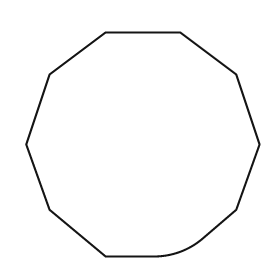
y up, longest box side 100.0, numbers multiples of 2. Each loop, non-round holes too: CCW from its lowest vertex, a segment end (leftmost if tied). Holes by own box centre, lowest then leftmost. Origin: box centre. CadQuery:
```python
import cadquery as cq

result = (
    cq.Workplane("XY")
    .moveTo(-16.0, -48.0)
    .lineTo(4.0, -48.0)
    .threePointArc((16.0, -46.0), (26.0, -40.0))
    .lineTo(40.0, -28.0)
    .lineTo(50.0, 0.0)
    .lineTo(40.0, 30.0)
    .lineTo(16.0, 48.0)
    .lineTo(-16.0, 48.0)
    .lineTo(-40.0, 30.0)
    .lineTo(-50.0, 0.0)
    .lineTo(-40.0, -28.0)
    .close()
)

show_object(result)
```